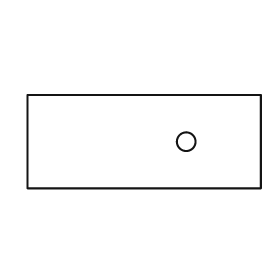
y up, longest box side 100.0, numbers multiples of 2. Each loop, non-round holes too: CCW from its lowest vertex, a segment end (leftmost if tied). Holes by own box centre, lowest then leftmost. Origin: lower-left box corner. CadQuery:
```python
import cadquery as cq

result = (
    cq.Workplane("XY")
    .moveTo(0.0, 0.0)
    .lineTo(100.0, 0.0)
    .lineTo(100.0, 40.0)
    .lineTo(0.0, 40.0)
    .close()
    .moveTo(68.0, 20.0)
    .circle(4.0)
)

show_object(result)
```